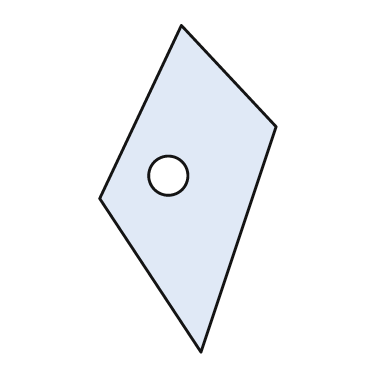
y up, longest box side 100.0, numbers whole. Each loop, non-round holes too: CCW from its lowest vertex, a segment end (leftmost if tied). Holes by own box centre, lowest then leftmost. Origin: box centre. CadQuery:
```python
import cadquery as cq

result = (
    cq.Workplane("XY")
    .moveTo(4.0, -50.0)
    .lineTo(27.0, 19.0)
    .lineTo(-2.0, 50.0)
    .lineTo(-27.0, -3.0)
    .close()
    .moveTo(-6.0, 4.0)
    .circle(6.0)
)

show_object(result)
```